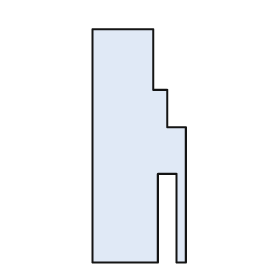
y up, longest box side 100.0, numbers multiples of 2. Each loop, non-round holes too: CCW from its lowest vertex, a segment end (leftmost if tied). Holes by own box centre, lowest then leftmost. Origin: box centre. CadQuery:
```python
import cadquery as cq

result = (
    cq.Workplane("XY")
    .moveTo(-20.0, -50.0)
    .lineTo(8.0, -50.0)
    .lineTo(8.0, -12.0)
    .lineTo(16.0, -12.0)
    .lineTo(16.0, -50.0)
    .lineTo(20.0, -50.0)
    .lineTo(20.0, 8.0)
    .lineTo(12.0, 8.0)
    .lineTo(12.0, 24.0)
    .lineTo(6.0, 24.0)
    .lineTo(6.0, 50.0)
    .lineTo(-20.0, 50.0)
    .close()
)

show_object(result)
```